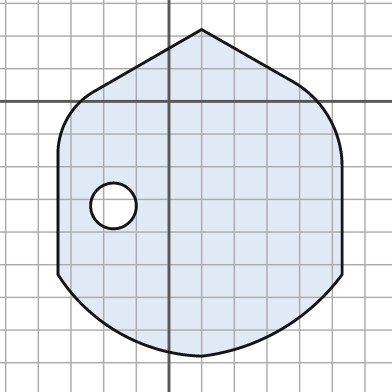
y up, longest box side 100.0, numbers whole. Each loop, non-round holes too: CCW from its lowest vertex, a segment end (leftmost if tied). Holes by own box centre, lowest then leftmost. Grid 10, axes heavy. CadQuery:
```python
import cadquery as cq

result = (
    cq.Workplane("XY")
    .moveTo(10.0, -78.0)
    .threePointArc((34.0, -70.0), (53.0, -53.0))
    .lineTo(53.0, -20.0)
    .threePointArc((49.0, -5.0), (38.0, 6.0))
    .lineTo(10.0, 22.0)
    .lineTo(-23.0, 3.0)
    .threePointArc((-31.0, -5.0), (-34.0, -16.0))
    .lineTo(-34.0, -53.0)
    .threePointArc((-15.0, -71.0), (10.0, -78.0))
    .close()
    .moveTo(-17.0, -32.0)
    .circle(7.0)
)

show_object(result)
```